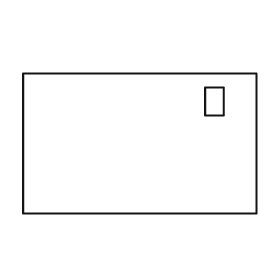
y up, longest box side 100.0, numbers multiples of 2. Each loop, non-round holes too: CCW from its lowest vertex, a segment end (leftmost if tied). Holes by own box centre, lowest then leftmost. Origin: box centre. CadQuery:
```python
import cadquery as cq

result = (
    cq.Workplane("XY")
    .moveTo(-50.0, -30.0)
    .lineTo(50.0, -30.0)
    .lineTo(50.0, 30.0)
    .lineTo(-50.0, 30.0)
    .close()
    .moveTo(28.0, 12.0)
    .lineTo(36.0, 12.0)
    .lineTo(36.0, 24.0)
    .lineTo(28.0, 24.0)
    .close()
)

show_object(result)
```